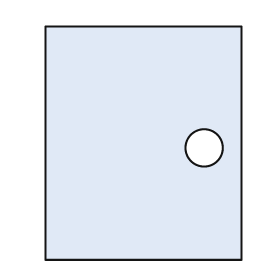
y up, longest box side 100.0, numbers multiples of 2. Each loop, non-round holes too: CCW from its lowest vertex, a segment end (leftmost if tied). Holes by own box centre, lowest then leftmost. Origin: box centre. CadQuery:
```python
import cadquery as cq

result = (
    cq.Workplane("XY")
    .moveTo(-42.0, -50.0)
    .lineTo(42.0, -50.0)
    .lineTo(42.0, 50.0)
    .lineTo(-42.0, 50.0)
    .close()
    .moveTo(26.0, -2.0)
    .circle(8.0)
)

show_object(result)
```